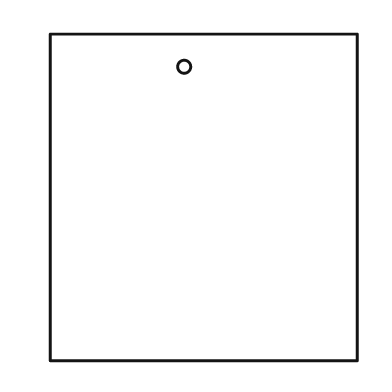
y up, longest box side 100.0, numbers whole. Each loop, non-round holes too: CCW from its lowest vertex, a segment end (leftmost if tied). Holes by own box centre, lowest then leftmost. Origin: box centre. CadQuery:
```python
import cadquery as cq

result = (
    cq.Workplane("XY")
    .moveTo(-47.0, -50.0)
    .lineTo(47.0, -50.0)
    .lineTo(47.0, 50.0)
    .lineTo(-47.0, 50.0)
    .close()
    .moveTo(-6.0, 40.0)
    .circle(2.0)
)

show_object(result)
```